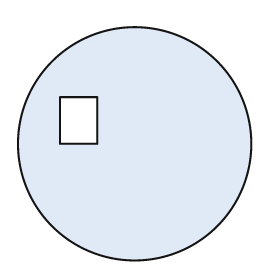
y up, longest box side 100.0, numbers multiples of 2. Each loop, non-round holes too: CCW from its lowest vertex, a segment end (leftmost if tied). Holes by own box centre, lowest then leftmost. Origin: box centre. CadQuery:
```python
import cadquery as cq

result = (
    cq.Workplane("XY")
    .moveTo(0.0, 0.0)
    .circle(50.0)
    .moveTo(-32.0, 0.0)
    .lineTo(-16.0, 0.0)
    .lineTo(-16.0, 20.0)
    .lineTo(-32.0, 20.0)
    .close()
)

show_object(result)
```